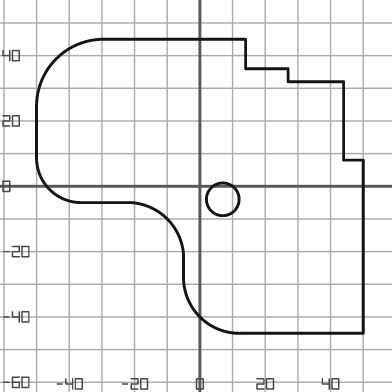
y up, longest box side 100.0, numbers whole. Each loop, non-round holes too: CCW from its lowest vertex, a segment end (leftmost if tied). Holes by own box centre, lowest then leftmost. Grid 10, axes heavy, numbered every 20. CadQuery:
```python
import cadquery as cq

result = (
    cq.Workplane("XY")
    .moveTo(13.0, -45.0)
    .lineTo(50.0, -45.0)
    .lineTo(50.0, 8.0)
    .lineTo(44.0, 8.0)
    .lineTo(44.0, 32.0)
    .lineTo(27.0, 32.0)
    .lineTo(27.0, 36.0)
    .lineTo(14.0, 36.0)
    .lineTo(14.0, 45.0)
    .lineTo(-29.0, 45.0)
    .threePointArc((-44.0, 39.0), (-50.0, 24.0))
    .lineTo(-50.0, 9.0)
    .threePointArc((-46.0, -1.0), (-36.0, -5.0))
    .lineTo(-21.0, -5.0)
    .threePointArc((-10.0, -10.0), (-5.0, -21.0))
    .lineTo(-5.0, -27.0)
    .threePointArc((0.0, -40.0), (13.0, -45.0))
    .close()
    .moveTo(7.0, -4.0)
    .circle(5.0)
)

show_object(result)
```